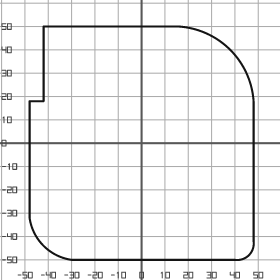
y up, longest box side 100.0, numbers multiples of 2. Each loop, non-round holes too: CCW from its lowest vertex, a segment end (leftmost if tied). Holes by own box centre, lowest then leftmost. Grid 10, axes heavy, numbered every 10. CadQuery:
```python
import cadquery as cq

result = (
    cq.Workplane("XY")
    .moveTo(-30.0, -50.0)
    .lineTo(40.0, -50.0)
    .threePointArc((46.0, -48.0), (48.0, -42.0))
    .lineTo(48.0, 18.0)
    .threePointArc((38.0, 40.0), (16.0, 50.0))
    .lineTo(-42.0, 50.0)
    .lineTo(-42.0, 18.0)
    .lineTo(-48.0, 18.0)
    .lineTo(-48.0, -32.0)
    .threePointArc((-42.0, -44.0), (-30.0, -50.0))
    .close()
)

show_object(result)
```